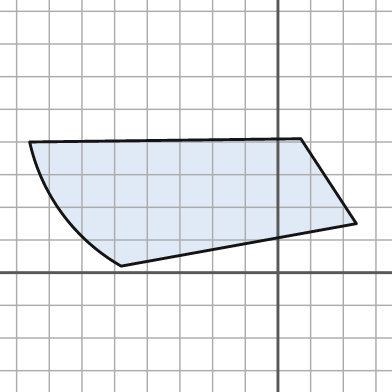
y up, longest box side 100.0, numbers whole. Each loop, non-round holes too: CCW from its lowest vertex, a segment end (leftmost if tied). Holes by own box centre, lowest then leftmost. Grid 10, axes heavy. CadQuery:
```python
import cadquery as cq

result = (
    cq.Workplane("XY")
    .moveTo(-48.0, 2.0)
    .lineTo(24.0, 15.0)
    .lineTo(7.0, 41.0)
    .lineTo(-76.0, 40.0)
    .threePointArc((-66.0, 18.0), (-48.0, 2.0))
    .close()
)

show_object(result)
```